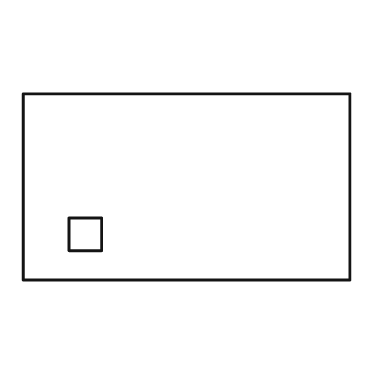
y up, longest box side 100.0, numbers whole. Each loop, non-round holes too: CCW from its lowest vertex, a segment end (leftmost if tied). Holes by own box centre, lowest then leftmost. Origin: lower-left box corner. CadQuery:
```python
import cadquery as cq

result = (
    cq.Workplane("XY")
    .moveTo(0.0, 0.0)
    .lineTo(100.0, 0.0)
    .lineTo(100.0, 57.0)
    .lineTo(0.0, 57.0)
    .close()
    .moveTo(14.0, 9.0)
    .lineTo(24.0, 9.0)
    .lineTo(24.0, 19.0)
    .lineTo(14.0, 19.0)
    .close()
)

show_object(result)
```